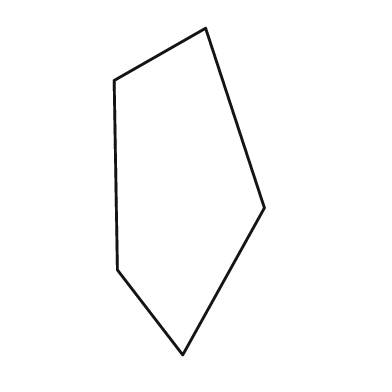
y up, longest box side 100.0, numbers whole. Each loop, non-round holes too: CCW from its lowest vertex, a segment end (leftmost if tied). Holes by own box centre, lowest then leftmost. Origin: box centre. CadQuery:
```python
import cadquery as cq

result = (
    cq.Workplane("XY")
    .moveTo(-2.0, -50.0)
    .lineTo(23.0, -5.0)
    .lineTo(5.0, 50.0)
    .lineTo(-23.0, 34.0)
    .lineTo(-22.0, -24.0)
    .close()
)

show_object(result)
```